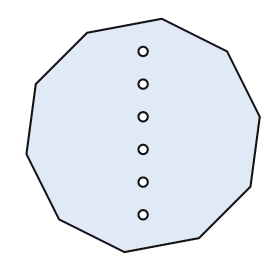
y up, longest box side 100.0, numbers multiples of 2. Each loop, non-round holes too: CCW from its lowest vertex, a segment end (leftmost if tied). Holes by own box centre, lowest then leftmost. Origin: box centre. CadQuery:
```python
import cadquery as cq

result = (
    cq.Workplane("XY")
    .moveTo(-8.0, -50.0)
    .lineTo(24.0, -44.0)
    .lineTo(46.0, -22.0)
    .lineTo(50.0, 8.0)
    .lineTo(36.0, 36.0)
    .lineTo(8.0, 50.0)
    .lineTo(-24.0, 44.0)
    .lineTo(-46.0, 22.0)
    .lineTo(-50.0, -8.0)
    .lineTo(-36.0, -36.0)
    .close()
    .moveTo(0.0, -34.0)
    .circle(2.0)
    .moveTo(0.0, -20.0)
    .circle(2.0)
    .moveTo(0.0, -6.0)
    .circle(2.0)
    .moveTo(0.0, 8.0)
    .circle(2.0)
    .moveTo(0.0, 22.0)
    .circle(2.0)
    .moveTo(0.0, 36.0)
    .circle(2.0)
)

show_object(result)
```